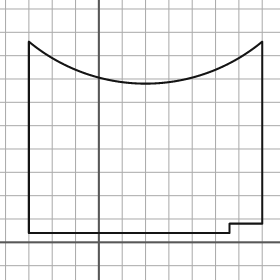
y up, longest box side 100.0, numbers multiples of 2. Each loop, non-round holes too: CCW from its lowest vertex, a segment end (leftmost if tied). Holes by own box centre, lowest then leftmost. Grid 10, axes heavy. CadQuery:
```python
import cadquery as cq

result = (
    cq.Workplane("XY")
    .moveTo(-30.0, 4.0)
    .lineTo(56.0, 4.0)
    .lineTo(56.0, 8.0)
    .lineTo(70.0, 8.0)
    .lineTo(70.0, 86.0)
    .threePointArc((20.0, 68.0), (-30.0, 86.0))
    .close()
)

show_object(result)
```